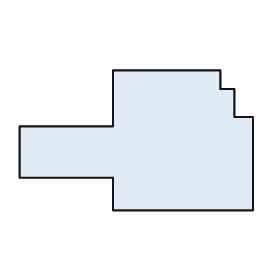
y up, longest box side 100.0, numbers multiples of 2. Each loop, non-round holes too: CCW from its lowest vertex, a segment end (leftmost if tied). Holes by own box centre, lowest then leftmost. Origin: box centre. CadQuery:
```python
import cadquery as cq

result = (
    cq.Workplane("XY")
    .moveTo(-10.0, -30.0)
    .lineTo(50.0, -30.0)
    .lineTo(50.0, 10.0)
    .lineTo(42.0, 10.0)
    .lineTo(42.0, 22.0)
    .lineTo(36.0, 22.0)
    .lineTo(36.0, 30.0)
    .lineTo(-10.0, 30.0)
    .lineTo(-10.0, 6.0)
    .lineTo(-50.0, 6.0)
    .lineTo(-50.0, -16.0)
    .lineTo(-10.0, -16.0)
    .close()
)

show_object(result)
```